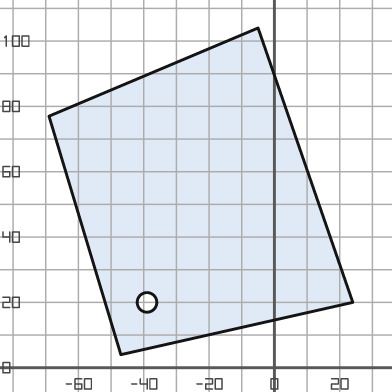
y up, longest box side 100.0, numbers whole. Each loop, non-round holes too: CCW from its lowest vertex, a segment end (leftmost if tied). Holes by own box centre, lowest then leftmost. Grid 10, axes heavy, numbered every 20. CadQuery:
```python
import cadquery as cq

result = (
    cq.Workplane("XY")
    .moveTo(-47.0, 4.0)
    .lineTo(24.0, 20.0)
    .lineTo(-5.0, 104.0)
    .lineTo(-69.0, 77.0)
    .close()
    .moveTo(-39.0, 20.0)
    .circle(3.0)
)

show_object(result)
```